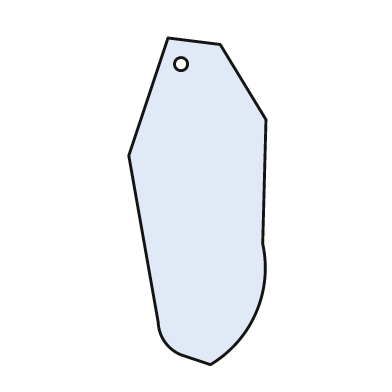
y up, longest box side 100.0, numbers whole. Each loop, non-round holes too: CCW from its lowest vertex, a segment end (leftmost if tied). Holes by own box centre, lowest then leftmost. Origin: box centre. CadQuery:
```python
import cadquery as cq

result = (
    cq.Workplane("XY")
    .moveTo(4.0, -50.0)
    .threePointArc((18.0, -34.0), (20.0, -13.0))
    .lineTo(21.0, 25.0)
    .lineTo(7.0, 48.0)
    .lineTo(-9.0, 50.0)
    .lineTo(-21.0, 14.0)
    .lineTo(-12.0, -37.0)
    .threePointArc((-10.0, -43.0), (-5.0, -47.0))
    .close()
    .moveTo(-5.0, 42.0)
    .circle(2.0)
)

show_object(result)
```